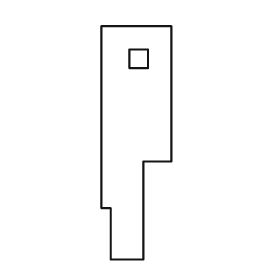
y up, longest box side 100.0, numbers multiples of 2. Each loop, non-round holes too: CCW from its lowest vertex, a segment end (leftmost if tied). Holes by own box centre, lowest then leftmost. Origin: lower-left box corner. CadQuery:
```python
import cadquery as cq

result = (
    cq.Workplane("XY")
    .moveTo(4.0, 0.0)
    .lineTo(18.0, 0.0)
    .lineTo(18.0, 42.0)
    .lineTo(30.0, 42.0)
    .lineTo(30.0, 100.0)
    .lineTo(0.0, 100.0)
    .lineTo(0.0, 22.0)
    .lineTo(4.0, 22.0)
    .close()
    .moveTo(12.0, 82.0)
    .lineTo(20.0, 82.0)
    .lineTo(20.0, 90.0)
    .lineTo(12.0, 90.0)
    .close()
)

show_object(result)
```